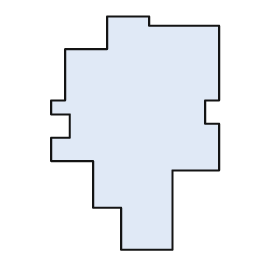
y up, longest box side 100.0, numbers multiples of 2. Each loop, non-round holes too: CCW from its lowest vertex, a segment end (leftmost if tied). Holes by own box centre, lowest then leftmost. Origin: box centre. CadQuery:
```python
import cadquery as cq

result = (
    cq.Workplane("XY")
    .moveTo(-6.0, -50.0)
    .lineTo(16.0, -50.0)
    .lineTo(16.0, -16.0)
    .lineTo(36.0, -16.0)
    .lineTo(36.0, 4.0)
    .lineTo(30.0, 4.0)
    .lineTo(30.0, 14.0)
    .lineTo(36.0, 14.0)
    .lineTo(36.0, 46.0)
    .lineTo(6.0, 46.0)
    .lineTo(6.0, 50.0)
    .lineTo(-12.0, 50.0)
    .lineTo(-12.0, 36.0)
    .lineTo(-30.0, 36.0)
    .lineTo(-30.0, 14.0)
    .lineTo(-36.0, 14.0)
    .lineTo(-36.0, 8.0)
    .lineTo(-28.0, 8.0)
    .lineTo(-28.0, -2.0)
    .lineTo(-36.0, -2.0)
    .lineTo(-36.0, -12.0)
    .lineTo(-18.0, -12.0)
    .lineTo(-18.0, -32.0)
    .lineTo(-6.0, -32.0)
    .close()
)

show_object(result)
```